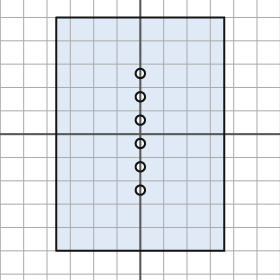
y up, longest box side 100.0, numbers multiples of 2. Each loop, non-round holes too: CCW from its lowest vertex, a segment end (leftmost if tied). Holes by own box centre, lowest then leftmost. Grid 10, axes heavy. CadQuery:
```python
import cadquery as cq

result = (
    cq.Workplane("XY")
    .moveTo(-36.0, -50.0)
    .lineTo(36.0, -50.0)
    .lineTo(36.0, 50.0)
    .lineTo(-36.0, 50.0)
    .close()
    .moveTo(0.0, -24.0)
    .circle(2.0)
    .moveTo(0.0, -14.0)
    .circle(2.0)
    .moveTo(0.0, -4.0)
    .circle(2.0)
    .moveTo(0.0, 6.0)
    .circle(2.0)
    .moveTo(0.0, 16.0)
    .circle(2.0)
    .moveTo(0.0, 26.0)
    .circle(2.0)
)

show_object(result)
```